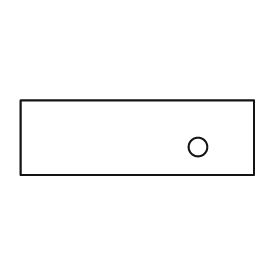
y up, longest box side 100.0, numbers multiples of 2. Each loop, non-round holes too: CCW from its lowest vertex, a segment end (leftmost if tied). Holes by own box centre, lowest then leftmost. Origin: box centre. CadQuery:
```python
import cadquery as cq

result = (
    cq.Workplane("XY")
    .moveTo(-50.0, -16.0)
    .lineTo(50.0, -16.0)
    .lineTo(50.0, 16.0)
    .lineTo(-50.0, 16.0)
    .close()
    .moveTo(26.0, -4.0)
    .circle(4.0)
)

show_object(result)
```